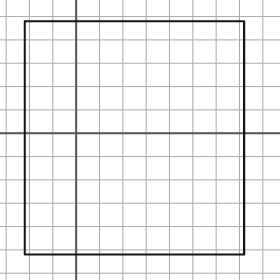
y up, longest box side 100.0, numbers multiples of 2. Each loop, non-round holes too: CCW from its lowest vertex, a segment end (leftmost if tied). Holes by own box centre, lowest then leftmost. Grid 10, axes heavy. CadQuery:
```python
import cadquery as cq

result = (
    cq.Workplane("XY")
    .moveTo(-22.0, -52.0)
    .lineTo(72.0, -52.0)
    .lineTo(72.0, 48.0)
    .lineTo(-22.0, 48.0)
    .close()
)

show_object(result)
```